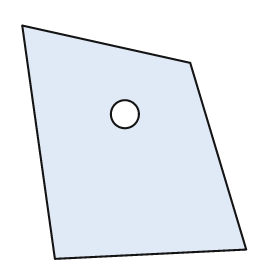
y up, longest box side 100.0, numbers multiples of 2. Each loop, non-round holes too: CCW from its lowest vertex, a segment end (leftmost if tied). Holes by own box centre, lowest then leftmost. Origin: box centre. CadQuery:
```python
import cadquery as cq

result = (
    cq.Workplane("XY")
    .moveTo(-34.0, -50.0)
    .lineTo(48.0, -46.0)
    .lineTo(24.0, 34.0)
    .lineTo(-48.0, 50.0)
    .close()
    .moveTo(-4.0, 12.0)
    .circle(6.0)
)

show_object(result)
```